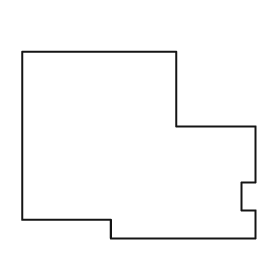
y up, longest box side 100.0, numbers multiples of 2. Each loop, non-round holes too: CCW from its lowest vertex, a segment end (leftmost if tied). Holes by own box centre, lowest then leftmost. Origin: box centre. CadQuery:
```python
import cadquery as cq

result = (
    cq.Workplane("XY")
    .moveTo(-12.0, -40.0)
    .lineTo(50.0, -40.0)
    .lineTo(50.0, -28.0)
    .lineTo(44.0, -28.0)
    .lineTo(44.0, -16.0)
    .lineTo(50.0, -16.0)
    .lineTo(50.0, 8.0)
    .lineTo(16.0, 8.0)
    .lineTo(16.0, 40.0)
    .lineTo(-50.0, 40.0)
    .lineTo(-50.0, -32.0)
    .lineTo(-12.0, -32.0)
    .close()
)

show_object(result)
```